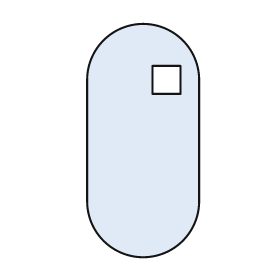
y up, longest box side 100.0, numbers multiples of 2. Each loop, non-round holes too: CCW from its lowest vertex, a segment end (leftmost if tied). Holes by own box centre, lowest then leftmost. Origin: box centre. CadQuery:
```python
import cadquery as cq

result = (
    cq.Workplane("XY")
    .moveTo(-24.0, -26.0)
    .threePointArc((0.0, -50.0), (24.0, -26.0))
    .lineTo(24.0, 26.0)
    .threePointArc((0.0, 50.0), (-24.0, 26.0))
    .close()
    .moveTo(4.0, 20.0)
    .lineTo(16.0, 20.0)
    .lineTo(16.0, 32.0)
    .lineTo(4.0, 32.0)
    .close()
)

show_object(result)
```